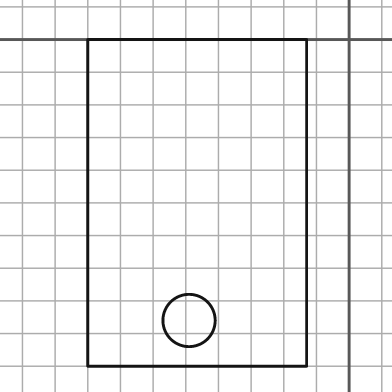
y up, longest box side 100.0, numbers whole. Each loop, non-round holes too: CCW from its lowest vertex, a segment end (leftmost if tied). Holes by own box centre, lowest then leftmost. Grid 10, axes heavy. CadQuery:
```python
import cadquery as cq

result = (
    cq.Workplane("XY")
    .moveTo(-80.0, -100.0)
    .lineTo(-13.0, -100.0)
    .lineTo(-13.0, 0.0)
    .lineTo(-80.0, 0.0)
    .close()
    .moveTo(-49.0, -86.0)
    .circle(8.0)
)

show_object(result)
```